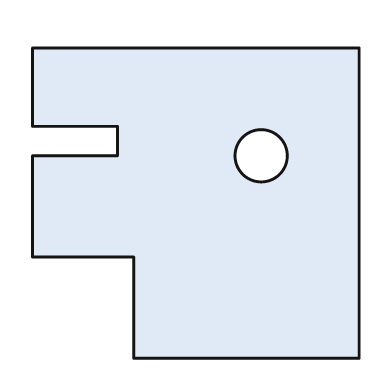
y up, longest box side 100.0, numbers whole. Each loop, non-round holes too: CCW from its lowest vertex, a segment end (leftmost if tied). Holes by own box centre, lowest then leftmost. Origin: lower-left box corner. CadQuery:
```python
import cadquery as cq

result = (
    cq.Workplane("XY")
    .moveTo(31.0, 0.0)
    .lineTo(100.0, 0.0)
    .lineTo(100.0, 95.0)
    .lineTo(0.0, 95.0)
    .lineTo(0.0, 71.0)
    .lineTo(26.0, 71.0)
    .lineTo(26.0, 62.0)
    .lineTo(0.0, 62.0)
    .lineTo(0.0, 31.0)
    .lineTo(31.0, 31.0)
    .close()
    .moveTo(70.0, 62.0)
    .circle(8.0)
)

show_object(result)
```